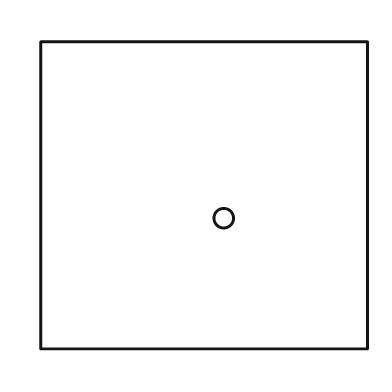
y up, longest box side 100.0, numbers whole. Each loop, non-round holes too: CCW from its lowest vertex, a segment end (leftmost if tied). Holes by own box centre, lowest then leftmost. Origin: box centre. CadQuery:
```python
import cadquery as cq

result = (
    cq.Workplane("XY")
    .moveTo(-50.0, -47.0)
    .lineTo(50.0, -47.0)
    .lineTo(50.0, 47.0)
    .lineTo(-50.0, 47.0)
    .close()
    .moveTo(6.0, -7.0)
    .circle(3.0)
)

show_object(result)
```